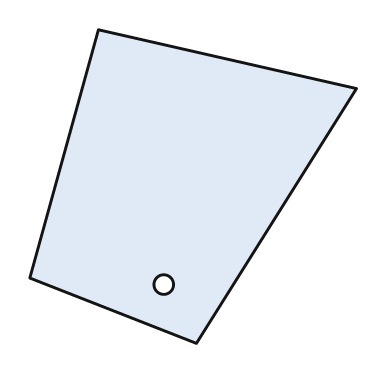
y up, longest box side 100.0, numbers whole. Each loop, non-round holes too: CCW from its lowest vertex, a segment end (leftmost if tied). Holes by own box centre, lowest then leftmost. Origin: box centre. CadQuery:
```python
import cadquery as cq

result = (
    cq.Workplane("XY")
    .moveTo(1.0, -48.0)
    .lineTo(50.0, 30.0)
    .lineTo(-29.0, 48.0)
    .lineTo(-50.0, -28.0)
    .close()
    .moveTo(-9.0, -30.0)
    .circle(3.0)
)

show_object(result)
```